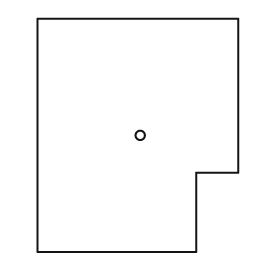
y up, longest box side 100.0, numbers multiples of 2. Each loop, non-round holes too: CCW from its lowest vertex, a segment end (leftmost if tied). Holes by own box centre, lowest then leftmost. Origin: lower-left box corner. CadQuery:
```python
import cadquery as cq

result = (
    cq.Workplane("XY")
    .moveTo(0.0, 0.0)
    .lineTo(68.0, 0.0)
    .lineTo(68.0, 34.0)
    .lineTo(86.0, 34.0)
    .lineTo(86.0, 100.0)
    .lineTo(0.0, 100.0)
    .close()
    .moveTo(44.0, 50.0)
    .circle(2.0)
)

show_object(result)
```